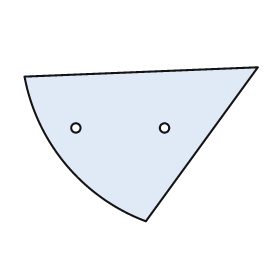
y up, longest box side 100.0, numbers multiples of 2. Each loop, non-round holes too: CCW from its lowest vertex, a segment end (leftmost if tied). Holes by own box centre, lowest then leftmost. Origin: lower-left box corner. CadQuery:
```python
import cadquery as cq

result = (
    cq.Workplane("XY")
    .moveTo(52.0, 0.0)
    .lineTo(100.0, 66.0)
    .lineTo(0.0, 62.0)
    .threePointArc((18.0, 24.0), (52.0, 0.0))
    .close()
    .moveTo(22.0, 40.0)
    .circle(2.0)
    .moveTo(60.0, 40.0)
    .circle(2.0)
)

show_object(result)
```